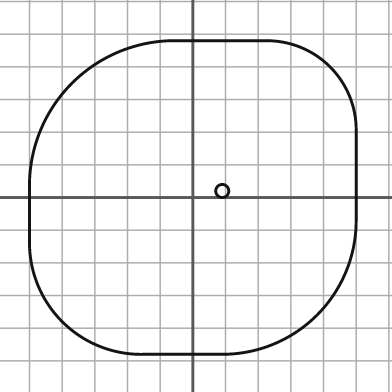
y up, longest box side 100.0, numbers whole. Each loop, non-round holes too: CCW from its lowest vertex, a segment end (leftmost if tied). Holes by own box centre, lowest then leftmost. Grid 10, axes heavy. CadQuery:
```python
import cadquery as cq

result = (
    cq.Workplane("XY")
    .moveTo(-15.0, -48.0)
    .lineTo(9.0, -48.0)
    .threePointArc((38.0, -36.0), (50.0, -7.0))
    .lineTo(50.0, 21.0)
    .threePointArc((42.0, 40.0), (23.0, 48.0))
    .lineTo(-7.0, 48.0)
    .threePointArc((-37.0, 35.0), (-50.0, 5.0))
    .lineTo(-50.0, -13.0)
    .threePointArc((-40.0, -38.0), (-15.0, -48.0))
    .close()
    .moveTo(9.0, 2.0)
    .circle(2.0)
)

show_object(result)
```